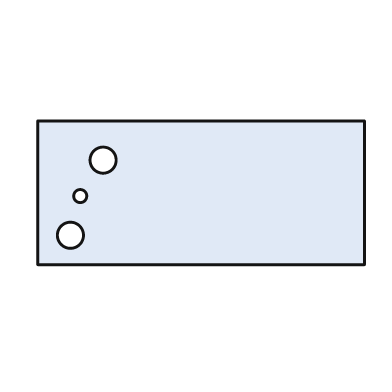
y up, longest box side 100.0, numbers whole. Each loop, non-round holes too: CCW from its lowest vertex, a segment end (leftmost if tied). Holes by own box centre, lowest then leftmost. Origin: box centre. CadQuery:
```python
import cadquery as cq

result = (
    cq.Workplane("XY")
    .moveTo(-50.0, -22.0)
    .lineTo(50.0, -22.0)
    .lineTo(50.0, 22.0)
    .lineTo(-50.0, 22.0)
    .close()
    .moveTo(-40.0, -13.0)
    .circle(4.0)
    .moveTo(-37.0, -1.0)
    .circle(2.0)
    .moveTo(-30.0, 10.0)
    .circle(4.0)
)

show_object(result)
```